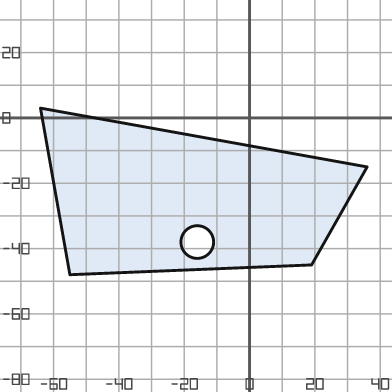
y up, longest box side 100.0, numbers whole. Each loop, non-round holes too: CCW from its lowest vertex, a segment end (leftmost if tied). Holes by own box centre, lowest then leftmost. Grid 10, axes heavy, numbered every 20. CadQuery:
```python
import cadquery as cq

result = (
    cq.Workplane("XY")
    .moveTo(-55.0, -48.0)
    .lineTo(19.0, -45.0)
    .lineTo(36.0, -15.0)
    .lineTo(-64.0, 3.0)
    .close()
    .moveTo(-16.0, -38.0)
    .circle(5.0)
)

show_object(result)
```